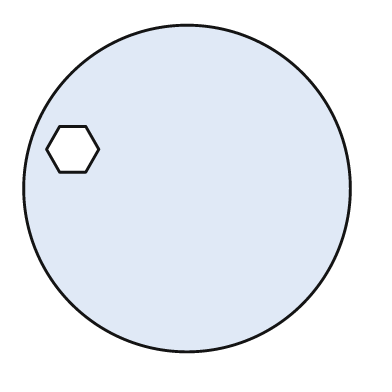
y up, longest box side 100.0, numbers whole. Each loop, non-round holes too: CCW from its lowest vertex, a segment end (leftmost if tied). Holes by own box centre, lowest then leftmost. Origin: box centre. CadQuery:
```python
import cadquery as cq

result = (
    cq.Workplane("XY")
    .moveTo(0.0, 0.0)
    .circle(50.0)
    .moveTo(-39.0, 5.0)
    .lineTo(-31.0, 5.0)
    .lineTo(-27.0, 12.0)
    .lineTo(-31.0, 19.0)
    .lineTo(-39.0, 19.0)
    .lineTo(-43.0, 12.0)
    .close()
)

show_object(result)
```